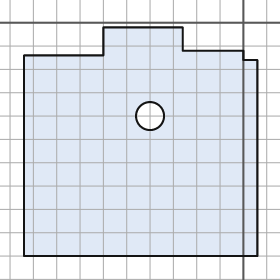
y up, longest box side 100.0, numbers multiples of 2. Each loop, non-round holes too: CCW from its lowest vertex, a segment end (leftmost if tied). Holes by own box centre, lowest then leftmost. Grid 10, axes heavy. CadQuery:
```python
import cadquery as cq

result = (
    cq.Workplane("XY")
    .moveTo(-94.0, -100.0)
    .lineTo(6.0, -100.0)
    .lineTo(6.0, -16.0)
    .lineTo(0.0, -16.0)
    .lineTo(0.0, -12.0)
    .lineTo(-26.0, -12.0)
    .lineTo(-26.0, -2.0)
    .lineTo(-60.0, -2.0)
    .lineTo(-60.0, -14.0)
    .lineTo(-94.0, -14.0)
    .close()
    .moveTo(-40.0, -40.0)
    .circle(6.0)
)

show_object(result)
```